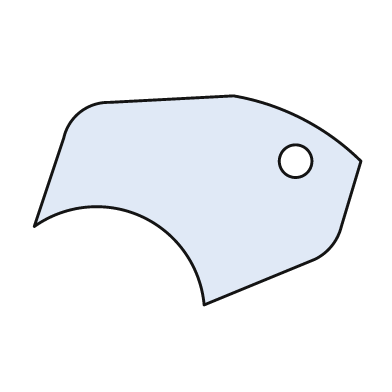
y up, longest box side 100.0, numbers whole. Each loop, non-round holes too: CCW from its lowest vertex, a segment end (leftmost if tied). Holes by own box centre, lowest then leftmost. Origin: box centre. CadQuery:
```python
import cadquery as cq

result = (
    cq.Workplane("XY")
    .moveTo(2.0, -32.0)
    .lineTo(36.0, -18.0)
    .threePointArc((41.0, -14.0), (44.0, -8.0))
    .lineTo(50.0, 12.0)
    .threePointArc((32.0, 25.0), (11.0, 32.0))
    .lineTo(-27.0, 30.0)
    .threePointArc((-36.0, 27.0), (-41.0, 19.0))
    .lineTo(-50.0, -8.0)
    .threePointArc((-17.0, -5.0), (2.0, -32.0))
    .close()
    .moveTo(30.0, 12.0)
    .circle(5.0)
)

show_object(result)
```